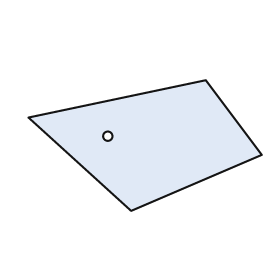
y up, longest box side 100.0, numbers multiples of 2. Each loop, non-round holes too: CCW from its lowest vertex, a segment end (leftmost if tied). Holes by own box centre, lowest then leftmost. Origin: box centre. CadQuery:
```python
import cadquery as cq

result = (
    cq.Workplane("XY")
    .moveTo(-6.0, -28.0)
    .lineTo(50.0, -4.0)
    .lineTo(26.0, 28.0)
    .lineTo(-50.0, 12.0)
    .close()
    .moveTo(-16.0, 4.0)
    .circle(2.0)
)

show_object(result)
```